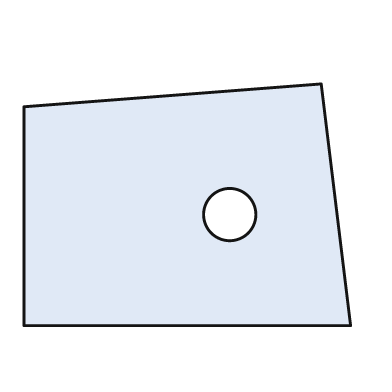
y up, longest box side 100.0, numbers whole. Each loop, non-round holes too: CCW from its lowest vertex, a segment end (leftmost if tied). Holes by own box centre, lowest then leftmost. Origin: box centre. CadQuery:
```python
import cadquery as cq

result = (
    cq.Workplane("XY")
    .moveTo(-50.0, -37.0)
    .lineTo(50.0, -37.0)
    .lineTo(41.0, 37.0)
    .lineTo(-50.0, 30.0)
    .close()
    .moveTo(13.0, -3.0)
    .circle(8.0)
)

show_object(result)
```